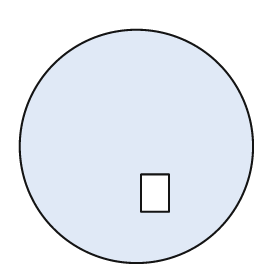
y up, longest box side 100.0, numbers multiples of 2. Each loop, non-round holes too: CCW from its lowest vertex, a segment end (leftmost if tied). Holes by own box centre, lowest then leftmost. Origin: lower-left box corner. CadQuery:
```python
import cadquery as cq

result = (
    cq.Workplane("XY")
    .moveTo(50.0, 50.0)
    .circle(50.0)
    .moveTo(52.0, 22.0)
    .lineTo(64.0, 22.0)
    .lineTo(64.0, 38.0)
    .lineTo(52.0, 38.0)
    .close()
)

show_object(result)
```